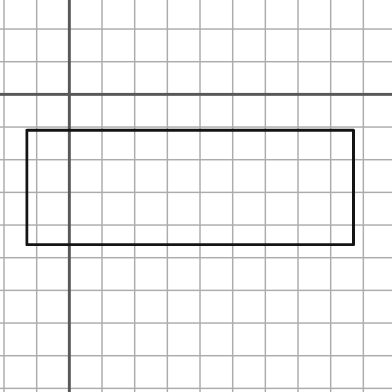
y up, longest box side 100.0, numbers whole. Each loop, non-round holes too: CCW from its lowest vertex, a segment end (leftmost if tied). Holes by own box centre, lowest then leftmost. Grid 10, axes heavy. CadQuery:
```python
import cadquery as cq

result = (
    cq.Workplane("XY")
    .moveTo(-13.0, -46.0)
    .lineTo(87.0, -46.0)
    .lineTo(87.0, -11.0)
    .lineTo(-13.0, -11.0)
    .close()
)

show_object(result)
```